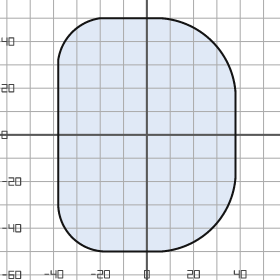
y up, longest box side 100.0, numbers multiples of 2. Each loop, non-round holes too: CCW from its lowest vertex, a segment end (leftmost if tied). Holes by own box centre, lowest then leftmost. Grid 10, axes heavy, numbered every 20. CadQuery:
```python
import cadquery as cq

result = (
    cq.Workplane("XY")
    .moveTo(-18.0, -50.0)
    .lineTo(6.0, -50.0)
    .threePointArc((28.0, -40.0), (38.0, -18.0))
    .lineTo(38.0, 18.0)
    .threePointArc((28.0, 40.0), (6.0, 50.0))
    .lineTo(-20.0, 50.0)
    .threePointArc((-32.0, 44.0), (-38.0, 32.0))
    .lineTo(-38.0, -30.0)
    .threePointArc((-32.0, -44.0), (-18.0, -50.0))
    .close()
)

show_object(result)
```